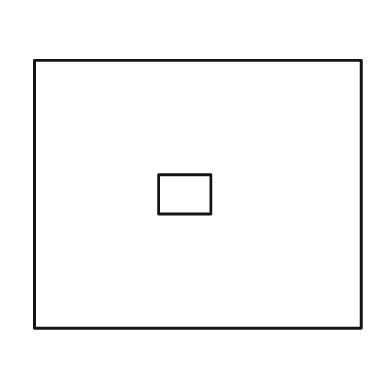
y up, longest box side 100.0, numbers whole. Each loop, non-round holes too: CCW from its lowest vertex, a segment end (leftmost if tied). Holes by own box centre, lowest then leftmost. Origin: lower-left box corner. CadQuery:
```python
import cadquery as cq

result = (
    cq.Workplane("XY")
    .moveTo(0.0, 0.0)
    .lineTo(100.0, 0.0)
    .lineTo(100.0, 82.0)
    .lineTo(0.0, 82.0)
    .close()
    .moveTo(38.0, 35.0)
    .lineTo(54.0, 35.0)
    .lineTo(54.0, 47.0)
    .lineTo(38.0, 47.0)
    .close()
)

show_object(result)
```